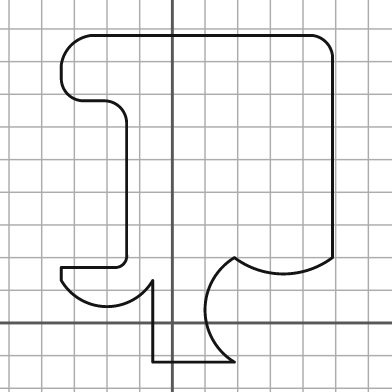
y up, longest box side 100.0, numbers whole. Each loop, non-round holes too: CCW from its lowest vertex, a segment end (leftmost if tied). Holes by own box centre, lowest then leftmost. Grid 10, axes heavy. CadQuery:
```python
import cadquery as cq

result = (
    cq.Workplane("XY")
    .moveTo(-6.0, -12.0)
    .lineTo(19.0, -12.0)
    .threePointArc((10.0, 4.0), (19.0, 20.0))
    .threePointArc((34.0, 15.0), (49.0, 20.0))
    .lineTo(49.0, 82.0)
    .threePointArc((47.0, 86.0), (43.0, 88.0))
    .lineTo(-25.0, 88.0)
    .threePointArc((-31.0, 85.0), (-34.0, 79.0))
    .lineTo(-34.0, 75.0)
    .threePointArc((-32.0, 70.0), (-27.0, 68.0))
    .lineTo(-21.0, 68.0)
    .threePointArc((-16.0, 66.0), (-14.0, 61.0))
    .lineTo(-14.0, 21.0)
    .threePointArc((-15.0, 18.0), (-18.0, 17.0))
    .lineTo(-34.0, 17.0)
    .lineTo(-34.0, 13.0)
    .threePointArc((-20.0, 5.0), (-6.0, 13.0))
    .close()
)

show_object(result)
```